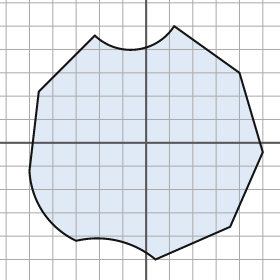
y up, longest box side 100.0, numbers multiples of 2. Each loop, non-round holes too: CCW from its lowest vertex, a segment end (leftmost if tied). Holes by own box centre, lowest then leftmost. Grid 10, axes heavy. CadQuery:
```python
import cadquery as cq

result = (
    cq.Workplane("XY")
    .moveTo(4.0, -50.0)
    .lineTo(36.0, -36.0)
    .lineTo(50.0, -4.0)
    .lineTo(40.0, 30.0)
    .lineTo(12.0, 50.0)
    .threePointArc((-4.0, 40.0), (-22.0, 46.0))
    .lineTo(-46.0, 22.0)
    .lineTo(-50.0, -12.0)
    .threePointArc((-44.0, -30.0), (-30.0, -42.0))
    .threePointArc((-12.0, -42.0), (4.0, -50.0))
    .close()
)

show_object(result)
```